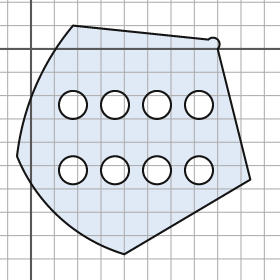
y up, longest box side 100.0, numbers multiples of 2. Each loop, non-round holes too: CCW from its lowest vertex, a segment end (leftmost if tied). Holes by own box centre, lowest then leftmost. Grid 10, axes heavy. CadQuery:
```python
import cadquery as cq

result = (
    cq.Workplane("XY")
    .moveTo(40.0, -88.0)
    .lineTo(94.0, -56.0)
    .lineTo(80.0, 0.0)
    .threePointArc((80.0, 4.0), (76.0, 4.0))
    .lineTo(18.0, 10.0)
    .threePointArc((2.0, -16.0), (-6.0, -46.0))
    .threePointArc((12.0, -72.0), (40.0, -88.0))
    .close()
    .moveTo(18.0, -52.0)
    .circle(6.0)
    .moveTo(36.0, -52.0)
    .circle(6.0)
    .moveTo(54.0, -52.0)
    .circle(6.0)
    .moveTo(72.0, -52.0)
    .circle(6.0)
    .moveTo(18.0, -24.0)
    .circle(6.0)
    .moveTo(36.0, -24.0)
    .circle(6.0)
    .moveTo(54.0, -24.0)
    .circle(6.0)
    .moveTo(72.0, -24.0)
    .circle(6.0)
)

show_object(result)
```